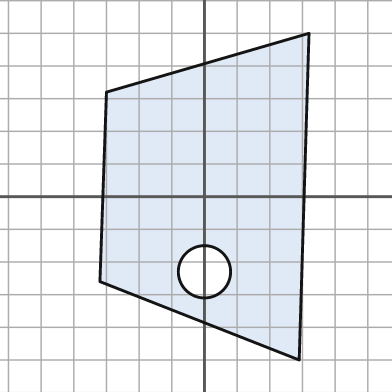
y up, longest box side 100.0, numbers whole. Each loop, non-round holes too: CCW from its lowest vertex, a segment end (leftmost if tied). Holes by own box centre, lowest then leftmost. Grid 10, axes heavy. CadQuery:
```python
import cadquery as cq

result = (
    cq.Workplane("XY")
    .moveTo(29.0, -50.0)
    .lineTo(32.0, 50.0)
    .lineTo(-30.0, 32.0)
    .lineTo(-32.0, -26.0)
    .close()
    .moveTo(0.0, -23.0)
    .circle(8.0)
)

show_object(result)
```